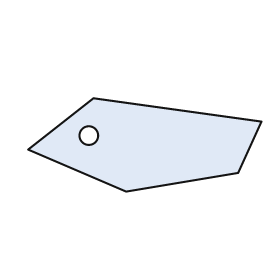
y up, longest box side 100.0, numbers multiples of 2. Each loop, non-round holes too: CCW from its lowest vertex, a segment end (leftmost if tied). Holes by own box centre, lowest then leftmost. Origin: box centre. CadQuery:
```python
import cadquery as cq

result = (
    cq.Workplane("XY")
    .moveTo(-8.0, -20.0)
    .lineTo(40.0, -12.0)
    .lineTo(50.0, 10.0)
    .lineTo(-22.0, 20.0)
    .lineTo(-50.0, -2.0)
    .close()
    .moveTo(-24.0, 4.0)
    .circle(4.0)
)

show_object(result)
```